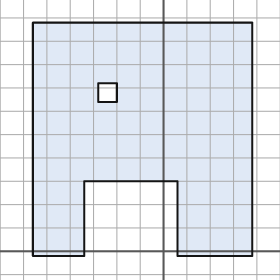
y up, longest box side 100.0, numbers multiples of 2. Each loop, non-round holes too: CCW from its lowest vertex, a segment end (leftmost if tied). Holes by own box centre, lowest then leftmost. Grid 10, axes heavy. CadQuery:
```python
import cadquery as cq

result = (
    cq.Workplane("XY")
    .moveTo(-56.0, -2.0)
    .lineTo(-34.0, -2.0)
    .lineTo(-34.0, 30.0)
    .lineTo(6.0, 30.0)
    .lineTo(6.0, -2.0)
    .lineTo(38.0, -2.0)
    .lineTo(38.0, 98.0)
    .lineTo(-56.0, 98.0)
    .close()
    .moveTo(-28.0, 64.0)
    .lineTo(-20.0, 64.0)
    .lineTo(-20.0, 72.0)
    .lineTo(-28.0, 72.0)
    .close()
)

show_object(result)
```